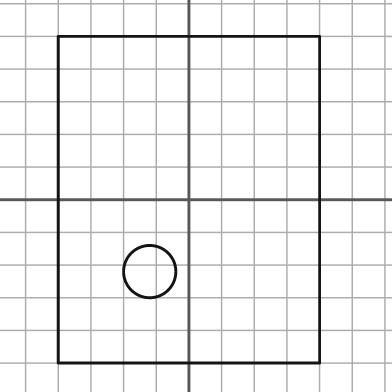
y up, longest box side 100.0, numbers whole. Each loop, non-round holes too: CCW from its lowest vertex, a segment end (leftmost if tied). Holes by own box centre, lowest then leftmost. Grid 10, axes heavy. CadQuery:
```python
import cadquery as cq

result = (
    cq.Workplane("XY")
    .moveTo(-40.0, -50.0)
    .lineTo(40.0, -50.0)
    .lineTo(40.0, 50.0)
    .lineTo(-40.0, 50.0)
    .close()
    .moveTo(-12.0, -22.0)
    .circle(8.0)
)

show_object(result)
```